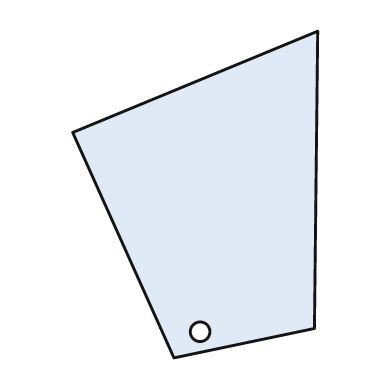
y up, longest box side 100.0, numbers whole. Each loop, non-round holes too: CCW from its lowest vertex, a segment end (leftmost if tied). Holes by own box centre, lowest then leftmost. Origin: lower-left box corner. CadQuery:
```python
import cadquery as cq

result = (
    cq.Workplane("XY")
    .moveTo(31.0, 0.0)
    .lineTo(74.0, 9.0)
    .lineTo(75.0, 100.0)
    .lineTo(0.0, 69.0)
    .close()
    .moveTo(39.0, 8.0)
    .circle(3.0)
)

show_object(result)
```